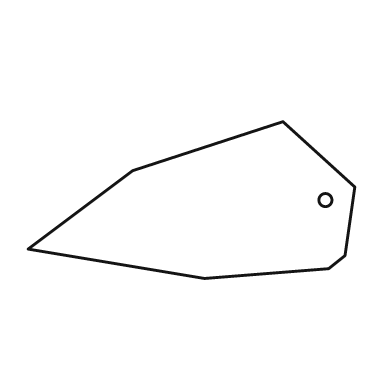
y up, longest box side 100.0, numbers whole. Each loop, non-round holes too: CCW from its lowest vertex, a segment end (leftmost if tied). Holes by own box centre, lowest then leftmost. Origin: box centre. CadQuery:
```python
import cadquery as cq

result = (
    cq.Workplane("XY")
    .moveTo(4.0, -24.0)
    .lineTo(42.0, -21.0)
    .lineTo(47.0, -17.0)
    .lineTo(50.0, 4.0)
    .lineTo(28.0, 24.0)
    .lineTo(-18.0, 9.0)
    .lineTo(-50.0, -15.0)
    .close()
    .moveTo(41.0, 0.0)
    .circle(2.0)
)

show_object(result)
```